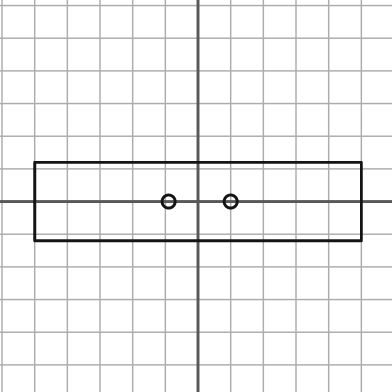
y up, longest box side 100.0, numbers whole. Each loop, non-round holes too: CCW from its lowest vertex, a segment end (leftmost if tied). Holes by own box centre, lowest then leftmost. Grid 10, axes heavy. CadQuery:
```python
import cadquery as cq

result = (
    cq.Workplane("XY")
    .moveTo(-50.0, -12.0)
    .lineTo(50.0, -12.0)
    .lineTo(50.0, 12.0)
    .lineTo(-50.0, 12.0)
    .close()
    .moveTo(-9.0, 0.0)
    .circle(2.0)
    .moveTo(10.0, 0.0)
    .circle(2.0)
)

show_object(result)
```